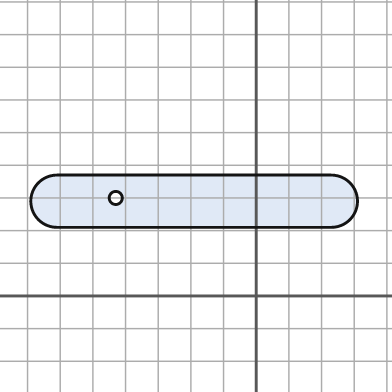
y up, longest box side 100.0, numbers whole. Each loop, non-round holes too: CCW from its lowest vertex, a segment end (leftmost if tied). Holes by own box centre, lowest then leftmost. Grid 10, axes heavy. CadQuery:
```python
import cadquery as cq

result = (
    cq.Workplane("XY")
    .moveTo(-61.0, 21.0)
    .lineTo(23.0, 21.0)
    .threePointArc((31.0, 29.0), (23.0, 37.0))
    .lineTo(-61.0, 37.0)
    .threePointArc((-69.0, 29.0), (-61.0, 21.0))
    .close()
    .moveTo(-43.0, 30.0)
    .circle(2.0)
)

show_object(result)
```